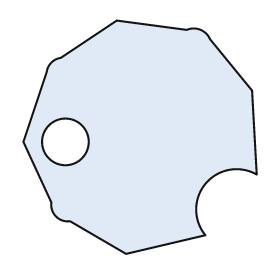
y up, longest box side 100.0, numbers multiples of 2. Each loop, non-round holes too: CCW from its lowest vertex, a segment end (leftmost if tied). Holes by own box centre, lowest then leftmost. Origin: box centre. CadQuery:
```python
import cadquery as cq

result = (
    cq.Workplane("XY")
    .moveTo(-6.0, -50.0)
    .lineTo(28.0, -42.0)
    .threePointArc((28.0, -20.0), (50.0, -16.0))
    .lineTo(48.0, 20.0)
    .lineTo(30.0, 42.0)
    .threePointArc((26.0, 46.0), (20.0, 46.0))
    .lineTo(-10.0, 50.0)
    .lineTo(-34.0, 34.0)
    .threePointArc((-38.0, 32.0), (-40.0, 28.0))
    .lineTo(-50.0, -2.0)
    .lineTo(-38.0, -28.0)
    .threePointArc((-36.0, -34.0), (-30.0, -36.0))
    .close()
    .moveTo(-32.0, -2.0)
    .circle(10.0)
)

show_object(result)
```